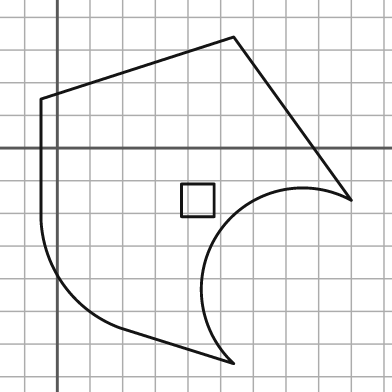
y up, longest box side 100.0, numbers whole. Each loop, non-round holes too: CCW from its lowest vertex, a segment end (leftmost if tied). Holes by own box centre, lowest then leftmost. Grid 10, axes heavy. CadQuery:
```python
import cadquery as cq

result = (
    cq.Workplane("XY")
    .moveTo(54.0, -66.0)
    .threePointArc((50.0, -25.0), (90.0, -16.0))
    .lineTo(54.0, 34.0)
    .lineTo(-5.0, 15.0)
    .lineTo(-5.0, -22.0)
    .threePointArc((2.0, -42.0), (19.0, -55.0))
    .close()
    .moveTo(38.0, -21.0)
    .lineTo(48.0, -21.0)
    .lineTo(48.0, -11.0)
    .lineTo(38.0, -11.0)
    .close()
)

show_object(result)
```